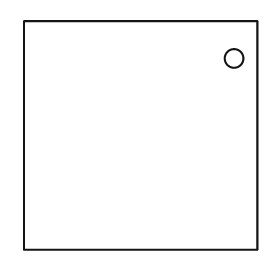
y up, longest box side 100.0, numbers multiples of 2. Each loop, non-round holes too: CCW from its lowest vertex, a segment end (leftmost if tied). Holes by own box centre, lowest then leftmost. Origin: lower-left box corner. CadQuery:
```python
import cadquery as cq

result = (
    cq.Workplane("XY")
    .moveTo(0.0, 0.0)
    .lineTo(100.0, 0.0)
    .lineTo(100.0, 98.0)
    .lineTo(0.0, 98.0)
    .close()
    .moveTo(90.0, 82.0)
    .circle(4.0)
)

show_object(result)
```